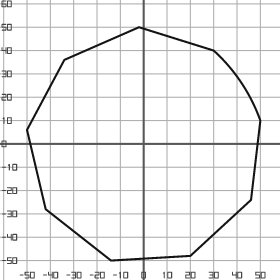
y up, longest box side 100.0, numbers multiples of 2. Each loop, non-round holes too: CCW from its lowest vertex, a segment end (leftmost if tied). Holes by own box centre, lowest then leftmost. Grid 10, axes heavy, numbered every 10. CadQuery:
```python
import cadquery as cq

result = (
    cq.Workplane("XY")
    .moveTo(-14.0, -50.0)
    .lineTo(20.0, -48.0)
    .lineTo(46.0, -24.0)
    .lineTo(50.0, 10.0)
    .threePointArc((42.0, 26.0), (30.0, 40.0))
    .lineTo(-2.0, 50.0)
    .lineTo(-34.0, 36.0)
    .lineTo(-50.0, 6.0)
    .lineTo(-42.0, -28.0)
    .close()
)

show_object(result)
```